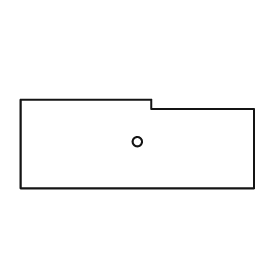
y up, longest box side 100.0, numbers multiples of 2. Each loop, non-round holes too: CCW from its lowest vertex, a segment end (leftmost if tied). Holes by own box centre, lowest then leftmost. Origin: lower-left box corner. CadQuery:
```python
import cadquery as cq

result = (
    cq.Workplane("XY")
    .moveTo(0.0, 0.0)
    .lineTo(100.0, 0.0)
    .lineTo(100.0, 34.0)
    .lineTo(56.0, 34.0)
    .lineTo(56.0, 38.0)
    .lineTo(0.0, 38.0)
    .close()
    .moveTo(50.0, 20.0)
    .circle(2.0)
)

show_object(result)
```